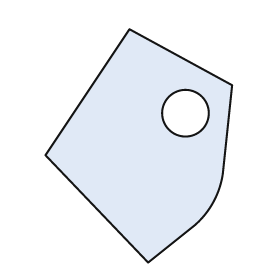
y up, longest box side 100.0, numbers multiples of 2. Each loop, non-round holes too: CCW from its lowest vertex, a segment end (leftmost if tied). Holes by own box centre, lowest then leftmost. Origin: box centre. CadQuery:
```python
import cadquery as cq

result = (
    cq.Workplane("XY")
    .moveTo(4.0, -50.0)
    .lineTo(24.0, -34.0)
    .threePointArc((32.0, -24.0), (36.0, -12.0))
    .lineTo(40.0, 26.0)
    .lineTo(-4.0, 50.0)
    .lineTo(-40.0, -4.0)
    .close()
    .moveTo(20.0, 14.0)
    .circle(10.0)
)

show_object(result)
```